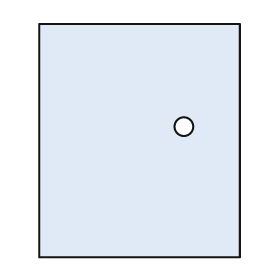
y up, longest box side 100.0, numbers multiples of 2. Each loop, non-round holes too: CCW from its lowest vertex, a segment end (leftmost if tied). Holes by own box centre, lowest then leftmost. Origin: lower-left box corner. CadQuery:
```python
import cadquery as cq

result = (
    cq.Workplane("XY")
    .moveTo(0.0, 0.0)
    .lineTo(86.0, 0.0)
    .lineTo(86.0, 100.0)
    .lineTo(0.0, 100.0)
    .close()
    .moveTo(62.0, 56.0)
    .circle(4.0)
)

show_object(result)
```